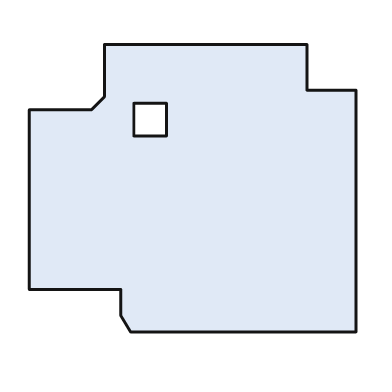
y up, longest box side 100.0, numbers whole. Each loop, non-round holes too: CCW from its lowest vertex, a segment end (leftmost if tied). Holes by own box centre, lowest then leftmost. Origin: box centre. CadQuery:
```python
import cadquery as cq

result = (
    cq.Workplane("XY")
    .moveTo(-19.0, -44.0)
    .lineTo(50.0, -44.0)
    .lineTo(50.0, 30.0)
    .lineTo(35.0, 30.0)
    .lineTo(35.0, 44.0)
    .lineTo(-27.0, 44.0)
    .lineTo(-27.0, 28.0)
    .lineTo(-31.0, 24.0)
    .lineTo(-50.0, 24.0)
    .lineTo(-50.0, -31.0)
    .lineTo(-22.0, -31.0)
    .lineTo(-22.0, -39.0)
    .close()
    .moveTo(-18.0, 16.0)
    .lineTo(-8.0, 16.0)
    .lineTo(-8.0, 26.0)
    .lineTo(-18.0, 26.0)
    .close()
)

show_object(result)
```